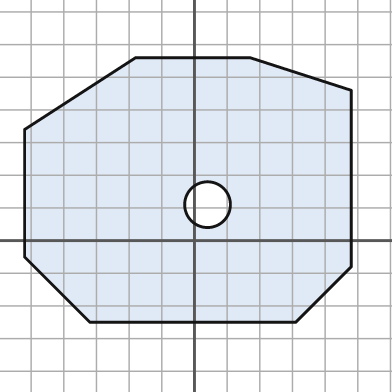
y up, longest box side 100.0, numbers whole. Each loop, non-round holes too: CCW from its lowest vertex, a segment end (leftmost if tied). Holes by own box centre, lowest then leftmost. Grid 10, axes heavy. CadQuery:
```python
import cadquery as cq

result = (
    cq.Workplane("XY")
    .moveTo(-32.0, -25.0)
    .lineTo(31.0, -25.0)
    .lineTo(48.0, -8.0)
    .lineTo(48.0, 46.0)
    .lineTo(17.0, 56.0)
    .lineTo(-18.0, 56.0)
    .lineTo(-52.0, 34.0)
    .lineTo(-52.0, -5.0)
    .close()
    .moveTo(4.0, 11.0)
    .circle(7.0)
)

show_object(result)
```